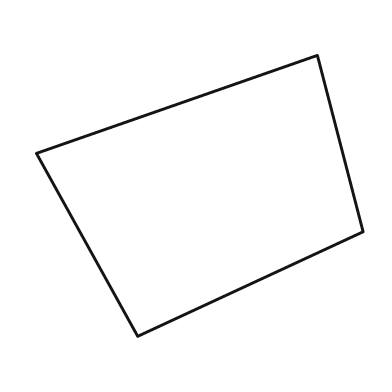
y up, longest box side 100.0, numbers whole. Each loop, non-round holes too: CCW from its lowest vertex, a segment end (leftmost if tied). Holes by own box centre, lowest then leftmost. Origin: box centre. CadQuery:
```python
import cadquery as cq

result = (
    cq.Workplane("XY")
    .moveTo(-19.0, -43.0)
    .lineTo(50.0, -11.0)
    .lineTo(36.0, 43.0)
    .lineTo(-50.0, 13.0)
    .close()
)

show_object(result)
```